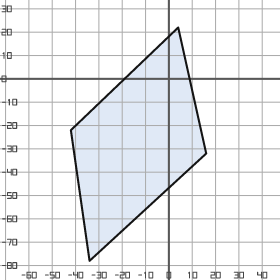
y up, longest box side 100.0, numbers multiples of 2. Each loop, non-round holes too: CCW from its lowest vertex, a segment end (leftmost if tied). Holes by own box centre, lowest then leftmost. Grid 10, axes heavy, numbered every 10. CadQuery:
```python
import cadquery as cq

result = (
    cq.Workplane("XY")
    .moveTo(-34.0, -78.0)
    .lineTo(16.0, -32.0)
    .lineTo(4.0, 22.0)
    .lineTo(-42.0, -22.0)
    .close()
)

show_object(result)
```